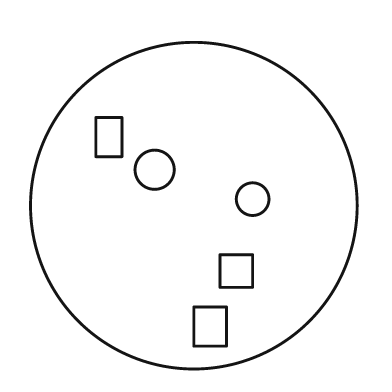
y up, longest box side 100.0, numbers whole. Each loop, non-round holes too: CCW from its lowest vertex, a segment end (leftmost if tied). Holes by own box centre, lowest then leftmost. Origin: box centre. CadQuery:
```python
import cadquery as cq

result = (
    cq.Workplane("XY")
    .moveTo(0.0, 0.0)
    .circle(50.0)
    .moveTo(0.0, -43.0)
    .lineTo(10.0, -43.0)
    .lineTo(10.0, -31.0)
    .lineTo(0.0, -31.0)
    .close()
    .moveTo(8.0, -25.0)
    .lineTo(18.0, -25.0)
    .lineTo(18.0, -15.0)
    .lineTo(8.0, -15.0)
    .close()
    .moveTo(18.0, 2.0)
    .circle(5.0)
    .moveTo(-12.0, 11.0)
    .circle(6.0)
    .moveTo(-30.0, 15.0)
    .lineTo(-22.0, 15.0)
    .lineTo(-22.0, 27.0)
    .lineTo(-30.0, 27.0)
    .close()
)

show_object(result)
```